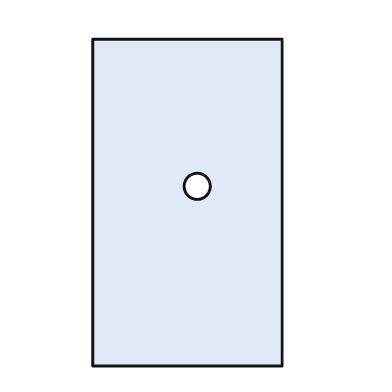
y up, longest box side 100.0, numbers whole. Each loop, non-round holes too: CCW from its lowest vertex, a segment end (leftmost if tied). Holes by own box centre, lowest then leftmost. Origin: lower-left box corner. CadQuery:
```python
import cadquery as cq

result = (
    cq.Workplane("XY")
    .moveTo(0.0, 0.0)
    .lineTo(58.0, 0.0)
    .lineTo(58.0, 100.0)
    .lineTo(0.0, 100.0)
    .close()
    .moveTo(32.0, 55.0)
    .circle(4.0)
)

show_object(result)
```